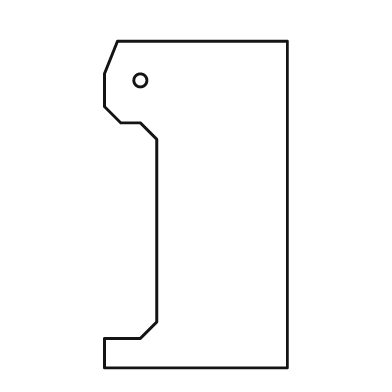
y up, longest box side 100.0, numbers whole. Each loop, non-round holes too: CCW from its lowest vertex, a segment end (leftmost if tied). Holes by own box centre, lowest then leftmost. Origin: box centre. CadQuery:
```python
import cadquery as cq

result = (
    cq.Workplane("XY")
    .moveTo(-28.0, -50.0)
    .lineTo(28.0, -50.0)
    .lineTo(28.0, 50.0)
    .lineTo(-24.0, 50.0)
    .lineTo(-28.0, 40.0)
    .lineTo(-28.0, 30.0)
    .lineTo(-23.0, 25.0)
    .lineTo(-17.0, 25.0)
    .lineTo(-12.0, 20.0)
    .lineTo(-12.0, -36.0)
    .lineTo(-17.0, -41.0)
    .lineTo(-28.0, -41.0)
    .close()
    .moveTo(-17.0, 38.0)
    .circle(2.0)
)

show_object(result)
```